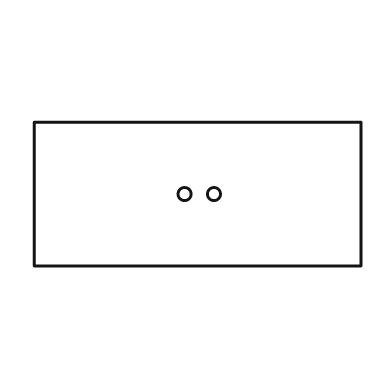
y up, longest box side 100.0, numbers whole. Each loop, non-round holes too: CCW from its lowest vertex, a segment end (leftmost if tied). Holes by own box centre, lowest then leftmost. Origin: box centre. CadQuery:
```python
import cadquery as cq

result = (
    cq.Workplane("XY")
    .moveTo(-50.0, -22.0)
    .lineTo(50.0, -22.0)
    .lineTo(50.0, 22.0)
    .lineTo(-50.0, 22.0)
    .close()
    .moveTo(-4.0, 0.0)
    .circle(2.0)
    .moveTo(5.0, 0.0)
    .circle(2.0)
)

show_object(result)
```